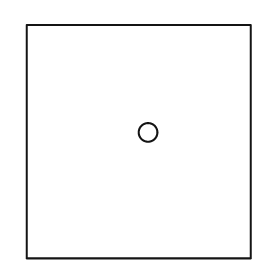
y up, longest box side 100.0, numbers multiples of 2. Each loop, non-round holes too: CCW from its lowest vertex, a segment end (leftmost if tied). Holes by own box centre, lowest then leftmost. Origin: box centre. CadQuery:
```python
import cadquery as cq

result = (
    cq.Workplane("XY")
    .moveTo(-48.0, -50.0)
    .lineTo(48.0, -50.0)
    .lineTo(48.0, 50.0)
    .lineTo(-48.0, 50.0)
    .close()
    .moveTo(4.0, 4.0)
    .circle(4.0)
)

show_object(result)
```